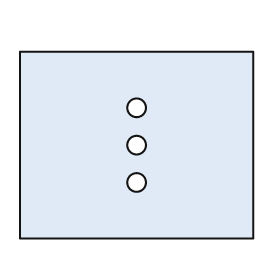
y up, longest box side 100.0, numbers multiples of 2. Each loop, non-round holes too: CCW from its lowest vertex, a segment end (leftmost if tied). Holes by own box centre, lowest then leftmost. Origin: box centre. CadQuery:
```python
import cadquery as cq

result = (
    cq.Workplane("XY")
    .moveTo(-50.0, -40.0)
    .lineTo(50.0, -40.0)
    .lineTo(50.0, 40.0)
    .lineTo(-50.0, 40.0)
    .close()
    .moveTo(0.0, -16.0)
    .circle(4.0)
    .moveTo(0.0, 0.0)
    .circle(4.0)
    .moveTo(0.0, 16.0)
    .circle(4.0)
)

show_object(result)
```